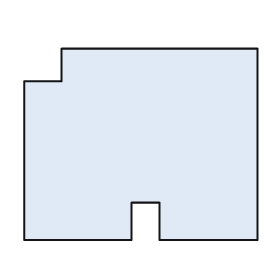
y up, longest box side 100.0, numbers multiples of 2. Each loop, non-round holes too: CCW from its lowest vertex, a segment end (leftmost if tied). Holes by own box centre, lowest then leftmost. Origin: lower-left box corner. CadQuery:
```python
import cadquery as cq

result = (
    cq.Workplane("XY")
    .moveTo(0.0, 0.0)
    .lineTo(46.0, 0.0)
    .lineTo(46.0, 16.0)
    .lineTo(58.0, 16.0)
    .lineTo(58.0, 0.0)
    .lineTo(100.0, 0.0)
    .lineTo(100.0, 82.0)
    .lineTo(16.0, 82.0)
    .lineTo(16.0, 68.0)
    .lineTo(0.0, 68.0)
    .close()
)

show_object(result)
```